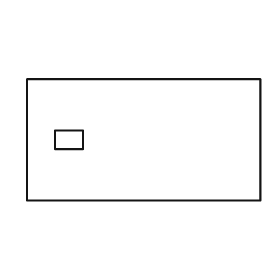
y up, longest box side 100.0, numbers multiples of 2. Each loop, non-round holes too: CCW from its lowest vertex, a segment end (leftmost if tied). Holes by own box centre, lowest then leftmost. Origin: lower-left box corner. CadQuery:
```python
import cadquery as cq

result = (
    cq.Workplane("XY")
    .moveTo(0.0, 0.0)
    .lineTo(100.0, 0.0)
    .lineTo(100.0, 52.0)
    .lineTo(0.0, 52.0)
    .close()
    .moveTo(12.0, 22.0)
    .lineTo(24.0, 22.0)
    .lineTo(24.0, 30.0)
    .lineTo(12.0, 30.0)
    .close()
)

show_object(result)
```